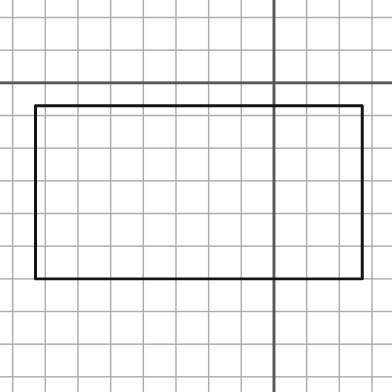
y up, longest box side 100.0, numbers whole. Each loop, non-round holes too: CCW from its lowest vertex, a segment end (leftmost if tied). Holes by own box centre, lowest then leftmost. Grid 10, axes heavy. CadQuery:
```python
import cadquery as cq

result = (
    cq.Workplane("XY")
    .moveTo(-73.0, -60.0)
    .lineTo(27.0, -60.0)
    .lineTo(27.0, -7.0)
    .lineTo(-73.0, -7.0)
    .close()
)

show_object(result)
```